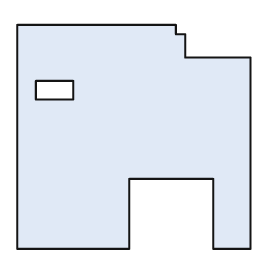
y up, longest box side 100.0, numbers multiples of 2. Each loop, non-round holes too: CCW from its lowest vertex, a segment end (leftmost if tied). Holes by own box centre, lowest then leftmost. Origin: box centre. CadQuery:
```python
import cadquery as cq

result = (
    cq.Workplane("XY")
    .moveTo(-50.0, -48.0)
    .lineTo(-2.0, -48.0)
    .lineTo(-2.0, -18.0)
    .lineTo(34.0, -18.0)
    .lineTo(34.0, -48.0)
    .lineTo(50.0, -48.0)
    .lineTo(50.0, 34.0)
    .lineTo(22.0, 34.0)
    .lineTo(22.0, 44.0)
    .lineTo(18.0, 44.0)
    .lineTo(18.0, 48.0)
    .lineTo(-50.0, 48.0)
    .close()
    .moveTo(-42.0, 16.0)
    .lineTo(-26.0, 16.0)
    .lineTo(-26.0, 24.0)
    .lineTo(-42.0, 24.0)
    .close()
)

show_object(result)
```